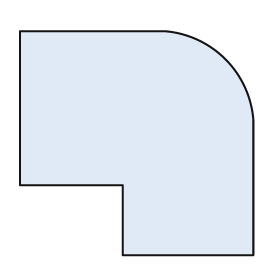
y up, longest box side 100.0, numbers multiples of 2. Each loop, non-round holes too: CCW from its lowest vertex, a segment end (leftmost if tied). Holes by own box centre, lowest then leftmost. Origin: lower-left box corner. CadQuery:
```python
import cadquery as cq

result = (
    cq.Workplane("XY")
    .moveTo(44.0, 0.0)
    .lineTo(100.0, 0.0)
    .lineTo(100.0, 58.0)
    .threePointArc((88.0, 84.0), (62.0, 96.0))
    .lineTo(0.0, 96.0)
    .lineTo(0.0, 30.0)
    .lineTo(44.0, 30.0)
    .close()
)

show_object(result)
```